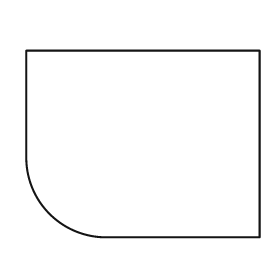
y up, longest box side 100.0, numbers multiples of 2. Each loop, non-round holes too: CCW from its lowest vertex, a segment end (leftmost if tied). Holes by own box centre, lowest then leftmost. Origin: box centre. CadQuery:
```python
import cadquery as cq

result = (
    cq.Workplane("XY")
    .moveTo(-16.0, -40.0)
    .lineTo(50.0, -40.0)
    .lineTo(50.0, 40.0)
    .lineTo(-50.0, 40.0)
    .lineTo(-50.0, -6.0)
    .threePointArc((-40.0, -30.0), (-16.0, -40.0))
    .close()
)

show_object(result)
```